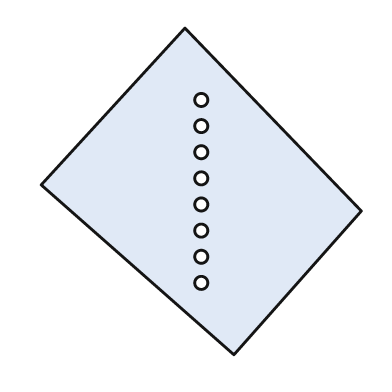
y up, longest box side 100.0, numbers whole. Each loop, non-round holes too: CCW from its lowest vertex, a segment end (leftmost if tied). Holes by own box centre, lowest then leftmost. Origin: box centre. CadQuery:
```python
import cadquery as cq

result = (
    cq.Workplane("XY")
    .moveTo(10.0, -50.0)
    .lineTo(49.0, -6.0)
    .lineTo(-5.0, 50.0)
    .lineTo(-49.0, 2.0)
    .close()
    .moveTo(0.0, -28.0)
    .circle(2.0)
    .moveTo(0.0, -20.0)
    .circle(2.0)
    .moveTo(0.0, -12.0)
    .circle(2.0)
    .moveTo(0.0, -4.0)
    .circle(2.0)
    .moveTo(0.0, 4.0)
    .circle(2.0)
    .moveTo(0.0, 12.0)
    .circle(2.0)
    .moveTo(0.0, 20.0)
    .circle(2.0)
    .moveTo(0.0, 28.0)
    .circle(2.0)
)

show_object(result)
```